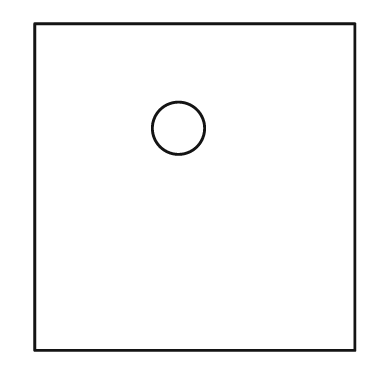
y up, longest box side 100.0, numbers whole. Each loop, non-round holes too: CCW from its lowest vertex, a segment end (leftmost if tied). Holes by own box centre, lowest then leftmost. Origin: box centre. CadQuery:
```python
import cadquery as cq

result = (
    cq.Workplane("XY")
    .moveTo(-49.0, -50.0)
    .lineTo(49.0, -50.0)
    .lineTo(49.0, 50.0)
    .lineTo(-49.0, 50.0)
    .close()
    .moveTo(-5.0, 18.0)
    .circle(8.0)
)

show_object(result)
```